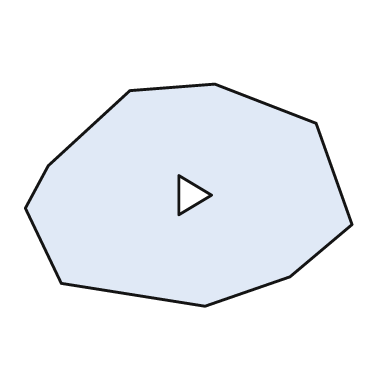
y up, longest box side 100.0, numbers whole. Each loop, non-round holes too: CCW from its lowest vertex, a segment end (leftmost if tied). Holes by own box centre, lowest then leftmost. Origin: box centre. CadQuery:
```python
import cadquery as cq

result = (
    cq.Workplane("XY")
    .moveTo(5.0, -34.0)
    .lineTo(31.0, -25.0)
    .lineTo(50.0, -9.0)
    .lineTo(39.0, 22.0)
    .lineTo(8.0, 34.0)
    .lineTo(-18.0, 32.0)
    .lineTo(-43.0, 9.0)
    .lineTo(-50.0, -4.0)
    .lineTo(-39.0, -27.0)
    .close()
    .moveTo(-3.0, -6.0)
    .lineTo(7.0, 0.0)
    .lineTo(-3.0, 6.0)
    .close()
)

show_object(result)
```